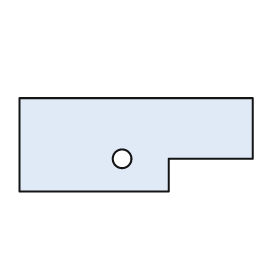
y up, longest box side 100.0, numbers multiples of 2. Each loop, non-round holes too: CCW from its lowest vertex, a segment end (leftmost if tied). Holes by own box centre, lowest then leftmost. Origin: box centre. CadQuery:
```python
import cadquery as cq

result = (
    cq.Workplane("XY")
    .moveTo(-50.0, -20.0)
    .lineTo(14.0, -20.0)
    .lineTo(14.0, -6.0)
    .lineTo(50.0, -6.0)
    .lineTo(50.0, 20.0)
    .lineTo(-50.0, 20.0)
    .close()
    .moveTo(-6.0, -6.0)
    .circle(4.0)
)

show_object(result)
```